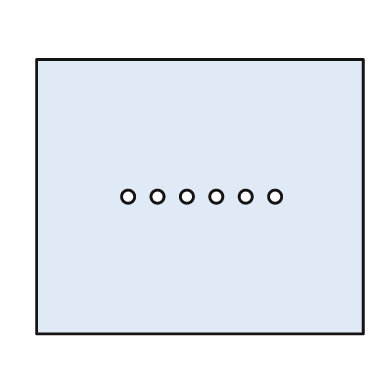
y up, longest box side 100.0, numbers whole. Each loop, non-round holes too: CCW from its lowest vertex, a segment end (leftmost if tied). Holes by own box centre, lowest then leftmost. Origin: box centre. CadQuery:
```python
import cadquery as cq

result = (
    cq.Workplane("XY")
    .moveTo(-50.0, -42.0)
    .lineTo(50.0, -42.0)
    .lineTo(50.0, 42.0)
    .lineTo(-50.0, 42.0)
    .close()
    .moveTo(-22.0, 0.0)
    .circle(2.0)
    .moveTo(-13.0, 0.0)
    .circle(2.0)
    .moveTo(-4.0, 0.0)
    .circle(2.0)
    .moveTo(5.0, 0.0)
    .circle(2.0)
    .moveTo(14.0, 0.0)
    .circle(2.0)
    .moveTo(23.0, 0.0)
    .circle(2.0)
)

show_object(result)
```